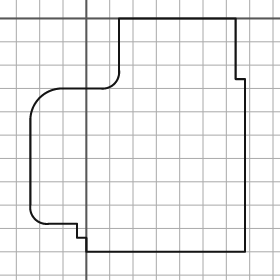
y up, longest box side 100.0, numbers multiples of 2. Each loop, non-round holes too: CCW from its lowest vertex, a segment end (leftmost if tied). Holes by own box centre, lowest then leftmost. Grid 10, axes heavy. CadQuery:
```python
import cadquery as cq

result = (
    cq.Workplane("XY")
    .moveTo(0.0, -100.0)
    .lineTo(68.0, -100.0)
    .lineTo(68.0, -26.0)
    .lineTo(64.0, -26.0)
    .lineTo(64.0, 0.0)
    .lineTo(14.0, 0.0)
    .lineTo(14.0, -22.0)
    .threePointArc((12.0, -28.0), (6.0, -30.0))
    .lineTo(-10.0, -30.0)
    .threePointArc((-20.0, -34.0), (-24.0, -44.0))
    .lineTo(-24.0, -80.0)
    .threePointArc((-22.0, -86.0), (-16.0, -88.0))
    .lineTo(-4.0, -88.0)
    .lineTo(-4.0, -94.0)
    .lineTo(0.0, -94.0)
    .close()
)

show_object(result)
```